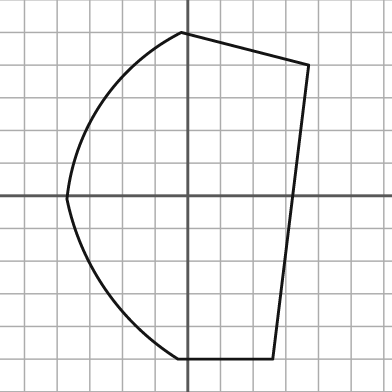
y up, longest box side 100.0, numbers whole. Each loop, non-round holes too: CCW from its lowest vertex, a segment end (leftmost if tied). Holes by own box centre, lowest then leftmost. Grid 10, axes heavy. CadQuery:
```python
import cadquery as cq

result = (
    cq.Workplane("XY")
    .moveTo(-3.0, -50.0)
    .lineTo(26.0, -50.0)
    .lineTo(37.0, 40.0)
    .lineTo(-2.0, 50.0)
    .threePointArc((-26.0, 29.0), (-37.0, -1.0))
    .threePointArc((-25.0, -29.0), (-3.0, -50.0))
    .close()
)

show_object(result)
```